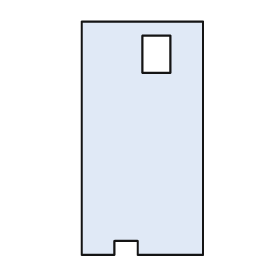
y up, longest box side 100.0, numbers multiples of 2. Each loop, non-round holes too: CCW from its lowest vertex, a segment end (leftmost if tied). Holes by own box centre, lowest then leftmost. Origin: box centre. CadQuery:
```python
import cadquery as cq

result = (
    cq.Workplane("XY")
    .moveTo(-26.0, -50.0)
    .lineTo(-12.0, -50.0)
    .lineTo(-12.0, -44.0)
    .lineTo(-2.0, -44.0)
    .lineTo(-2.0, -50.0)
    .lineTo(26.0, -50.0)
    .lineTo(26.0, 50.0)
    .lineTo(-26.0, 50.0)
    .close()
    .moveTo(0.0, 28.0)
    .lineTo(12.0, 28.0)
    .lineTo(12.0, 44.0)
    .lineTo(0.0, 44.0)
    .close()
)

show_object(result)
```